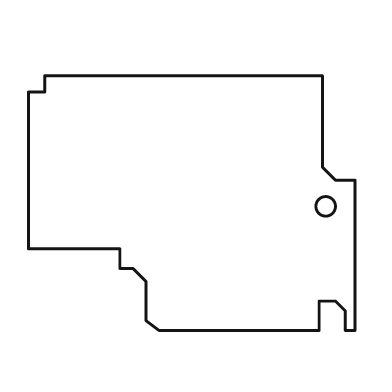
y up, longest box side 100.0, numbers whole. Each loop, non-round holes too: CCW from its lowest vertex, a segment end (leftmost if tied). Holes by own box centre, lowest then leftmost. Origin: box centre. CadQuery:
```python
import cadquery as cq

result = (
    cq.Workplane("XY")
    .moveTo(-10.0, -39.0)
    .lineTo(39.0, -39.0)
    .lineTo(39.0, -30.0)
    .lineTo(44.0, -30.0)
    .lineTo(47.0, -33.0)
    .lineTo(47.0, -39.0)
    .lineTo(50.0, -39.0)
    .lineTo(50.0, 7.0)
    .lineTo(44.0, 7.0)
    .lineTo(40.0, 11.0)
    .lineTo(40.0, 39.0)
    .lineTo(-45.0, 39.0)
    .lineTo(-45.0, 34.0)
    .lineTo(-50.0, 34.0)
    .lineTo(-50.0, -14.0)
    .lineTo(-22.0, -14.0)
    .lineTo(-22.0, -20.0)
    .lineTo(-18.0, -20.0)
    .lineTo(-14.0, -24.0)
    .lineTo(-14.0, -36.0)
    .close()
    .moveTo(41.0, -1.0)
    .circle(3.0)
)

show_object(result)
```